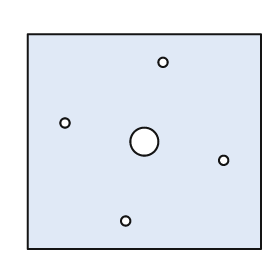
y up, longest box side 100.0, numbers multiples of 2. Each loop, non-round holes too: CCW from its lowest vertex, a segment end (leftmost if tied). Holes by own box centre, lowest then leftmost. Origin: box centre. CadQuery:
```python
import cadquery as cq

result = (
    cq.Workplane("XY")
    .moveTo(-50.0, -46.0)
    .lineTo(50.0, -46.0)
    .lineTo(50.0, 46.0)
    .lineTo(-50.0, 46.0)
    .close()
    .moveTo(-8.0, -34.0)
    .circle(2.0)
    .moveTo(34.0, -8.0)
    .circle(2.0)
    .moveTo(0.0, 0.0)
    .circle(6.0)
    .moveTo(-34.0, 8.0)
    .circle(2.0)
    .moveTo(8.0, 34.0)
    .circle(2.0)
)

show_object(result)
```